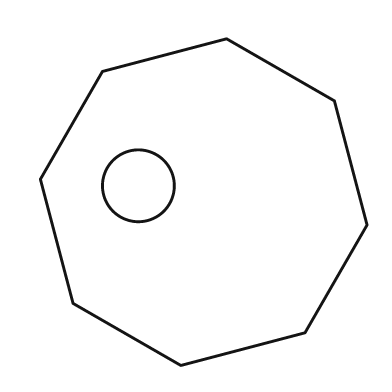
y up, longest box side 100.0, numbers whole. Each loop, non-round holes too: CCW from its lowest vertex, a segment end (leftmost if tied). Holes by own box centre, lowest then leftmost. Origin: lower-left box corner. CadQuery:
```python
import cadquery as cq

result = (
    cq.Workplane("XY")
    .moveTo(43.0, 0.0)
    .lineTo(81.0, 10.0)
    .lineTo(100.0, 43.0)
    .lineTo(90.0, 81.0)
    .lineTo(57.0, 100.0)
    .lineTo(19.0, 90.0)
    .lineTo(0.0, 57.0)
    .lineTo(10.0, 19.0)
    .close()
    .moveTo(30.0, 55.0)
    .circle(11.0)
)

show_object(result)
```